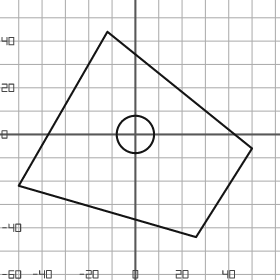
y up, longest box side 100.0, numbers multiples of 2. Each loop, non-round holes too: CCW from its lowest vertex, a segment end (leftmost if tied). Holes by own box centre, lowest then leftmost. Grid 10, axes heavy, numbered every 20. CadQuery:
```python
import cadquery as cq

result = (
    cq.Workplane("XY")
    .moveTo(26.0, -44.0)
    .lineTo(50.0, -6.0)
    .lineTo(-12.0, 44.0)
    .lineTo(-50.0, -22.0)
    .close()
    .moveTo(0.0, 0.0)
    .circle(8.0)
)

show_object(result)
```